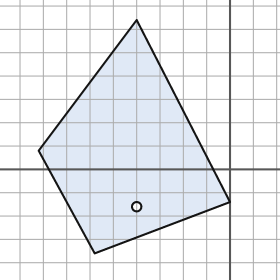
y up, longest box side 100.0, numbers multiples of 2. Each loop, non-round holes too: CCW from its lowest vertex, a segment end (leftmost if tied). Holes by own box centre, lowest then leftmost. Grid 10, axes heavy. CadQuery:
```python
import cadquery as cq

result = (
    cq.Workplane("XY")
    .moveTo(-58.0, -36.0)
    .lineTo(0.0, -14.0)
    .lineTo(-40.0, 64.0)
    .lineTo(-82.0, 8.0)
    .close()
    .moveTo(-40.0, -16.0)
    .circle(2.0)
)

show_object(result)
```